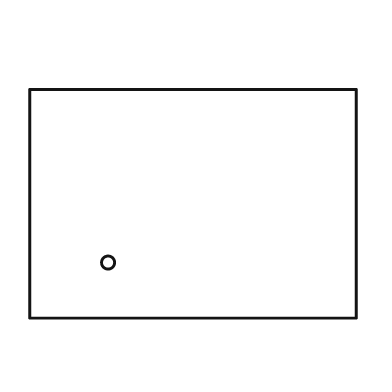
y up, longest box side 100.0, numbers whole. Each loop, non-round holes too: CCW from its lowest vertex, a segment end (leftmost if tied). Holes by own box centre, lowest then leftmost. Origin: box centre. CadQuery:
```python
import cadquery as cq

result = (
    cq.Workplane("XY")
    .moveTo(-50.0, -35.0)
    .lineTo(50.0, -35.0)
    .lineTo(50.0, 35.0)
    .lineTo(-50.0, 35.0)
    .close()
    .moveTo(-26.0, -18.0)
    .circle(2.0)
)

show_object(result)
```